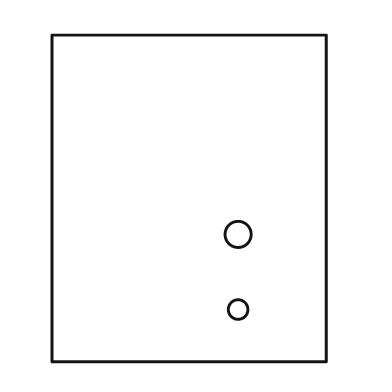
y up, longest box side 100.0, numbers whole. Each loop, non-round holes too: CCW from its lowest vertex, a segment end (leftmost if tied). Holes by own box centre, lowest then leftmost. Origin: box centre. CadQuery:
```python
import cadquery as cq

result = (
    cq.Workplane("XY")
    .moveTo(-42.0, -50.0)
    .lineTo(42.0, -50.0)
    .lineTo(42.0, 50.0)
    .lineTo(-42.0, 50.0)
    .close()
    .moveTo(15.0, -34.0)
    .circle(3.0)
    .moveTo(15.0, -11.0)
    .circle(4.0)
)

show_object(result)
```